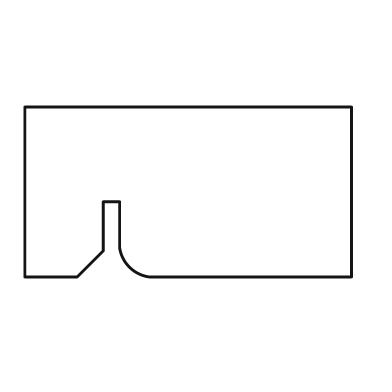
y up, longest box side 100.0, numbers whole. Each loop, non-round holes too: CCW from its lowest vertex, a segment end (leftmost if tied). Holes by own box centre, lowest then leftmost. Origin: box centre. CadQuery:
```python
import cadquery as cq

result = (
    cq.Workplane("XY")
    .moveTo(-50.0, -26.0)
    .lineTo(-34.0, -26.0)
    .lineTo(-26.0, -18.0)
    .lineTo(-26.0, -3.0)
    .lineTo(-21.0, -3.0)
    .lineTo(-21.0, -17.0)
    .threePointArc((-18.0, -23.0), (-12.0, -26.0))
    .lineTo(50.0, -26.0)
    .lineTo(50.0, 26.0)
    .lineTo(-50.0, 26.0)
    .close()
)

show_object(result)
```